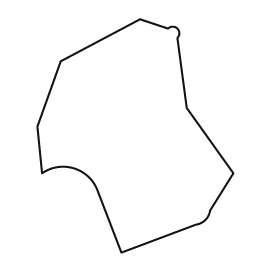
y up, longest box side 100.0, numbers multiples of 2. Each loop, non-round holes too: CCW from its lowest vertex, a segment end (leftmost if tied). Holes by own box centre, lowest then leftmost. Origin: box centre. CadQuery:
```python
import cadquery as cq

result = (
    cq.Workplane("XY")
    .moveTo(-6.0, -50.0)
    .lineTo(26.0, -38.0)
    .threePointArc((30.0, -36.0), (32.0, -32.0))
    .lineTo(42.0, -16.0)
    .lineTo(22.0, 12.0)
    .lineTo(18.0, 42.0)
    .threePointArc((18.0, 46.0), (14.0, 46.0))
    .lineTo(2.0, 50.0)
    .lineTo(-32.0, 32.0)
    .lineTo(-42.0, 4.0)
    .lineTo(-40.0, -16.0)
    .threePointArc((-26.0, -14.0), (-16.0, -24.0))
    .close()
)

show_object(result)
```